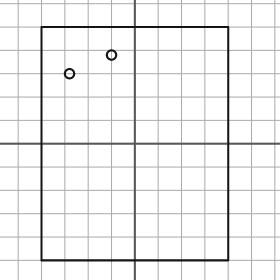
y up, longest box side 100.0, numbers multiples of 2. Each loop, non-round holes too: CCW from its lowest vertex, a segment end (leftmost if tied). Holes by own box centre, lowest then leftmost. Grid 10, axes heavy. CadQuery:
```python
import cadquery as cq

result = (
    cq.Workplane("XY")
    .moveTo(-40.0, -50.0)
    .lineTo(40.0, -50.0)
    .lineTo(40.0, 50.0)
    .lineTo(-40.0, 50.0)
    .close()
    .moveTo(-28.0, 30.0)
    .circle(2.0)
    .moveTo(-10.0, 38.0)
    .circle(2.0)
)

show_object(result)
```